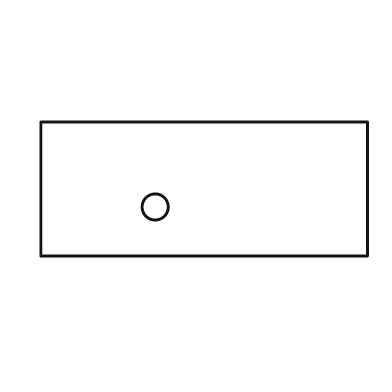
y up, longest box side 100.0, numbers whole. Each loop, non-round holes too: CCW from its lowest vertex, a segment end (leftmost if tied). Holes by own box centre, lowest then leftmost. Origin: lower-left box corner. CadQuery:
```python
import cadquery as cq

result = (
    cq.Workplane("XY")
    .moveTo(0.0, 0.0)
    .lineTo(100.0, 0.0)
    .lineTo(100.0, 41.0)
    .lineTo(0.0, 41.0)
    .close()
    .moveTo(35.0, 15.0)
    .circle(4.0)
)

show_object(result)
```